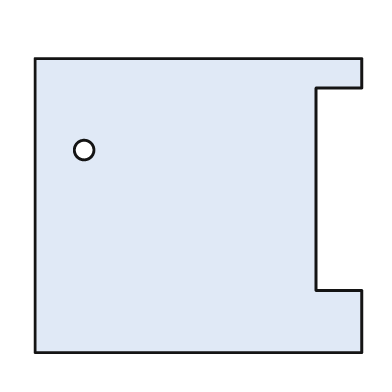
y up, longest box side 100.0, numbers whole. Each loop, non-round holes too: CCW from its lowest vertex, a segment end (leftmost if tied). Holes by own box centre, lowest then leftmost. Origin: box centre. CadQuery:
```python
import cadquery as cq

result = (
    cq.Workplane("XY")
    .moveTo(-50.0, -45.0)
    .lineTo(50.0, -45.0)
    .lineTo(50.0, -26.0)
    .lineTo(36.0, -26.0)
    .lineTo(36.0, 36.0)
    .lineTo(50.0, 36.0)
    .lineTo(50.0, 45.0)
    .lineTo(-50.0, 45.0)
    .close()
    .moveTo(-35.0, 17.0)
    .circle(3.0)
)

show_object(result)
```